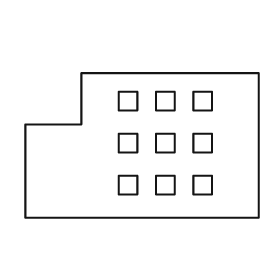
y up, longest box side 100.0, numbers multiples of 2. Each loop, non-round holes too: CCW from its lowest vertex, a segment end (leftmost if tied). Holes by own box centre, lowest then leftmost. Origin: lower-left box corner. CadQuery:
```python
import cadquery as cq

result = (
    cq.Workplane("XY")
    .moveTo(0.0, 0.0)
    .lineTo(100.0, 0.0)
    .lineTo(100.0, 62.0)
    .lineTo(24.0, 62.0)
    .lineTo(24.0, 40.0)
    .lineTo(0.0, 40.0)
    .close()
    .moveTo(40.0, 10.0)
    .lineTo(48.0, 10.0)
    .lineTo(48.0, 18.0)
    .lineTo(40.0, 18.0)
    .close()
    .moveTo(56.0, 10.0)
    .lineTo(64.0, 10.0)
    .lineTo(64.0, 18.0)
    .lineTo(56.0, 18.0)
    .close()
    .moveTo(72.0, 10.0)
    .lineTo(80.0, 10.0)
    .lineTo(80.0, 18.0)
    .lineTo(72.0, 18.0)
    .close()
    .moveTo(40.0, 28.0)
    .lineTo(48.0, 28.0)
    .lineTo(48.0, 36.0)
    .lineTo(40.0, 36.0)
    .close()
    .moveTo(56.0, 28.0)
    .lineTo(64.0, 28.0)
    .lineTo(64.0, 36.0)
    .lineTo(56.0, 36.0)
    .close()
    .moveTo(72.0, 28.0)
    .lineTo(80.0, 28.0)
    .lineTo(80.0, 36.0)
    .lineTo(72.0, 36.0)
    .close()
    .moveTo(40.0, 46.0)
    .lineTo(48.0, 46.0)
    .lineTo(48.0, 54.0)
    .lineTo(40.0, 54.0)
    .close()
    .moveTo(56.0, 46.0)
    .lineTo(64.0, 46.0)
    .lineTo(64.0, 54.0)
    .lineTo(56.0, 54.0)
    .close()
    .moveTo(72.0, 46.0)
    .lineTo(80.0, 46.0)
    .lineTo(80.0, 54.0)
    .lineTo(72.0, 54.0)
    .close()
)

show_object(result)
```